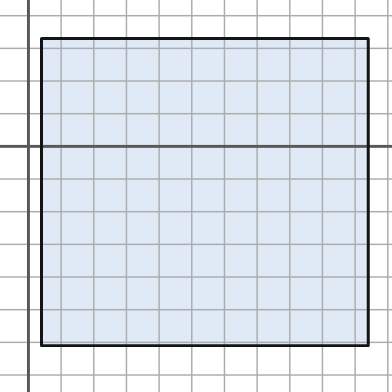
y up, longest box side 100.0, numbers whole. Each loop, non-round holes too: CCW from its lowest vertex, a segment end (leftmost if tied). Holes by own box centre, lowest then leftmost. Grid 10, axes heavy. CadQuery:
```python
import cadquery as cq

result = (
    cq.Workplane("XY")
    .moveTo(4.0, -61.0)
    .lineTo(104.0, -61.0)
    .lineTo(104.0, 33.0)
    .lineTo(4.0, 33.0)
    .close()
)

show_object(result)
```